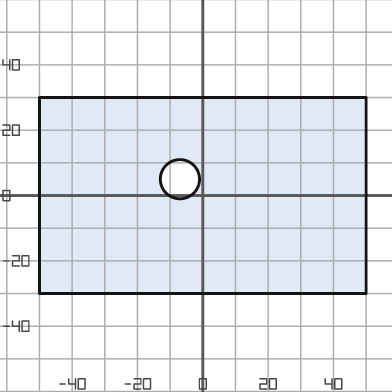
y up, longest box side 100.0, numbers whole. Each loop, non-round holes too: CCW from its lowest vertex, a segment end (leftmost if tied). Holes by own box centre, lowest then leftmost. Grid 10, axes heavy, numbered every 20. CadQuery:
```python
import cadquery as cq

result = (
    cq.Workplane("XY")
    .moveTo(-50.0, -30.0)
    .lineTo(50.0, -30.0)
    .lineTo(50.0, 30.0)
    .lineTo(-50.0, 30.0)
    .close()
    .moveTo(-7.0, 5.0)
    .circle(6.0)
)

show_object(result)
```